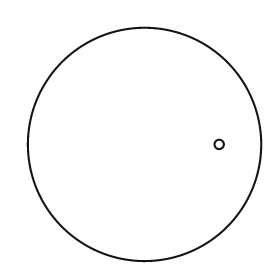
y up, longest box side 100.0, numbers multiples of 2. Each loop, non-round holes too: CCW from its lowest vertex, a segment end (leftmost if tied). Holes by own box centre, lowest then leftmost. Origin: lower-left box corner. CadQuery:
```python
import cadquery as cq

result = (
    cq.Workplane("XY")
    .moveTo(50.0, 50.0)
    .circle(50.0)
    .moveTo(82.0, 50.0)
    .circle(2.0)
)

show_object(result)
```